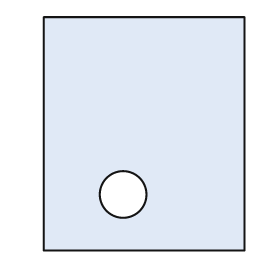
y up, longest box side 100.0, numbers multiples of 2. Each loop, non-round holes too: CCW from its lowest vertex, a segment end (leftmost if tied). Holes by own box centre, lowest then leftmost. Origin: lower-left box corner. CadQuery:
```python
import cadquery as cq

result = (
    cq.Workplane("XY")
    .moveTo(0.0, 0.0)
    .lineTo(86.0, 0.0)
    .lineTo(86.0, 100.0)
    .lineTo(0.0, 100.0)
    .close()
    .moveTo(34.0, 24.0)
    .circle(10.0)
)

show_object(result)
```